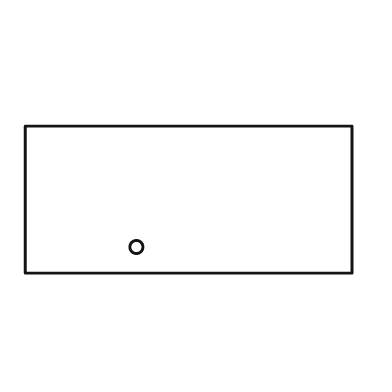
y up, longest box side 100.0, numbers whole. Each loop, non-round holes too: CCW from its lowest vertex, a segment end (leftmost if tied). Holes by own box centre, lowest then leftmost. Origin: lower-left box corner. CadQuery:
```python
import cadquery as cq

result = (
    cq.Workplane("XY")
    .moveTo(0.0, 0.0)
    .lineTo(100.0, 0.0)
    .lineTo(100.0, 45.0)
    .lineTo(0.0, 45.0)
    .close()
    .moveTo(34.0, 8.0)
    .circle(2.0)
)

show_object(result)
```